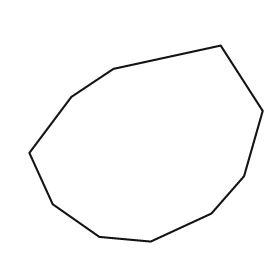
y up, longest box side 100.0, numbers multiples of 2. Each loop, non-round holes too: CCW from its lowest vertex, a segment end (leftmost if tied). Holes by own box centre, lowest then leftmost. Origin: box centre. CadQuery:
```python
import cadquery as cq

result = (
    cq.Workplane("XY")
    .moveTo(2.0, -42.0)
    .lineTo(28.0, -30.0)
    .lineTo(42.0, -14.0)
    .lineTo(50.0, 14.0)
    .lineTo(32.0, 42.0)
    .lineTo(-14.0, 32.0)
    .lineTo(-32.0, 20.0)
    .lineTo(-50.0, -4.0)
    .lineTo(-40.0, -26.0)
    .lineTo(-20.0, -40.0)
    .close()
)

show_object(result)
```